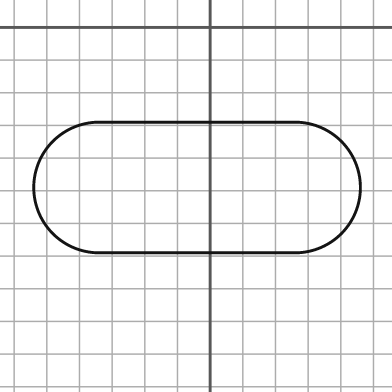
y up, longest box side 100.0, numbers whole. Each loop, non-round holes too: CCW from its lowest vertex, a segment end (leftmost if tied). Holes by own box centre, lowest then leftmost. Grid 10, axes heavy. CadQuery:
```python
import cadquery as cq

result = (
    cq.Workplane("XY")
    .moveTo(-34.0, -69.0)
    .lineTo(26.0, -69.0)
    .threePointArc((46.0, -49.0), (26.0, -29.0))
    .lineTo(-34.0, -29.0)
    .threePointArc((-54.0, -49.0), (-34.0, -69.0))
    .close()
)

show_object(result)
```